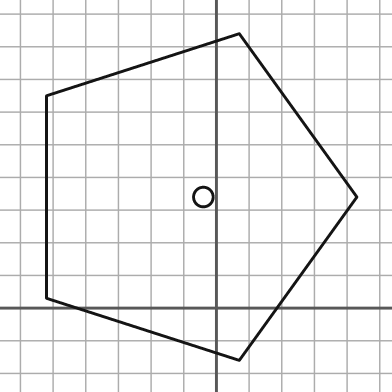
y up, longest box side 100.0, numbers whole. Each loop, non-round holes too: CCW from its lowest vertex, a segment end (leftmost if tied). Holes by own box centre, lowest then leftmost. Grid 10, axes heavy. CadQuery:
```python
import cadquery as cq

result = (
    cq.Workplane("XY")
    .moveTo(7.0, -16.0)
    .lineTo(43.0, 34.0)
    .lineTo(7.0, 84.0)
    .lineTo(-52.0, 65.0)
    .lineTo(-52.0, 3.0)
    .close()
    .moveTo(-4.0, 34.0)
    .circle(3.0)
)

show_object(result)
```